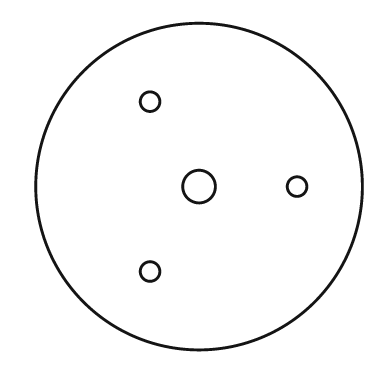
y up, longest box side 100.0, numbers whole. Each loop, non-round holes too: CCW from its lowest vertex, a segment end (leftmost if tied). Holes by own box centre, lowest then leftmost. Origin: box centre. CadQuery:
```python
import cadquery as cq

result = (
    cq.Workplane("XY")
    .moveTo(0.0, 0.0)
    .circle(50.0)
    .moveTo(-15.0, -26.0)
    .circle(3.0)
    .moveTo(0.0, 0.0)
    .circle(5.0)
    .moveTo(30.0, 0.0)
    .circle(3.0)
    .moveTo(-15.0, 26.0)
    .circle(3.0)
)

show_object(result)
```